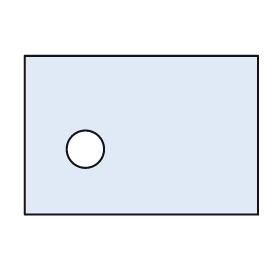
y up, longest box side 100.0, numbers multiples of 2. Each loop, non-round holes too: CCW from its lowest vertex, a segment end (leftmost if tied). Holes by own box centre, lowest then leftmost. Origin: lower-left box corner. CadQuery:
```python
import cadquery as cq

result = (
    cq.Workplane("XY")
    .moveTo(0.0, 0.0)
    .lineTo(100.0, 0.0)
    .lineTo(100.0, 68.0)
    .lineTo(0.0, 68.0)
    .close()
    .moveTo(26.0, 28.0)
    .circle(8.0)
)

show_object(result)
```